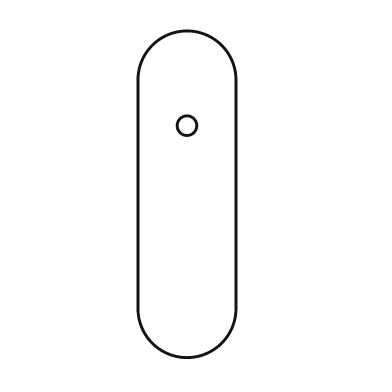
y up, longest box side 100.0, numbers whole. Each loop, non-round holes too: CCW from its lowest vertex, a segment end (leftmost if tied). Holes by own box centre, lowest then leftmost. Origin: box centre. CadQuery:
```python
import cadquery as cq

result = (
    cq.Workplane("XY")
    .moveTo(-15.0, -35.0)
    .threePointArc((0.0, -50.0), (15.0, -35.0))
    .lineTo(15.0, 35.0)
    .threePointArc((0.0, 50.0), (-15.0, 35.0))
    .close()
    .moveTo(0.0, 21.0)
    .circle(3.0)
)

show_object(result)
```